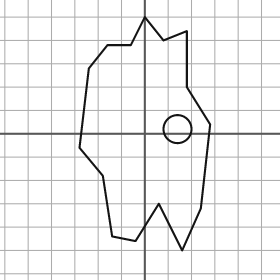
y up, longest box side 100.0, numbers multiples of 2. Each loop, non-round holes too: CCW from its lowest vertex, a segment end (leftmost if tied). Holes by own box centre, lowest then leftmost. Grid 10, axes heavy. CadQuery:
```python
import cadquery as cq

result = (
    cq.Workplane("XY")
    .moveTo(16.0, -50.0)
    .lineTo(24.0, -32.0)
    .lineTo(28.0, 4.0)
    .lineTo(18.0, 20.0)
    .lineTo(18.0, 44.0)
    .lineTo(8.0, 40.0)
    .lineTo(0.0, 50.0)
    .lineTo(-6.0, 38.0)
    .lineTo(-16.0, 38.0)
    .lineTo(-24.0, 28.0)
    .lineTo(-28.0, -6.0)
    .lineTo(-18.0, -18.0)
    .lineTo(-14.0, -44.0)
    .lineTo(-4.0, -46.0)
    .lineTo(6.0, -30.0)
    .close()
    .moveTo(14.0, 2.0)
    .circle(6.0)
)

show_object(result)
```